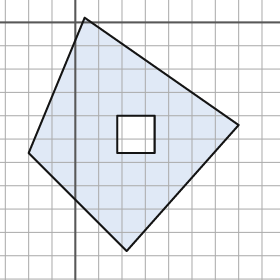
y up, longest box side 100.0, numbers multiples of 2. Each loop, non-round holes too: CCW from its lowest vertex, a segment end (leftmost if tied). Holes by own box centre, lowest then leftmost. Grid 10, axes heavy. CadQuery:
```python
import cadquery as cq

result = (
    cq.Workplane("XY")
    .moveTo(22.0, -98.0)
    .lineTo(70.0, -44.0)
    .lineTo(4.0, 2.0)
    .lineTo(-20.0, -56.0)
    .close()
    .moveTo(18.0, -56.0)
    .lineTo(34.0, -56.0)
    .lineTo(34.0, -40.0)
    .lineTo(18.0, -40.0)
    .close()
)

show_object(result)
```